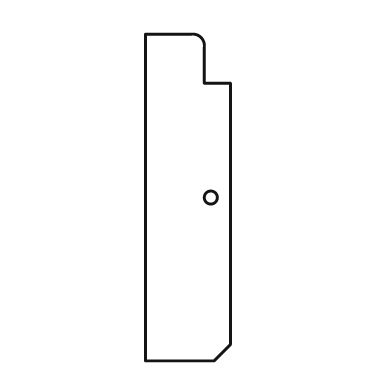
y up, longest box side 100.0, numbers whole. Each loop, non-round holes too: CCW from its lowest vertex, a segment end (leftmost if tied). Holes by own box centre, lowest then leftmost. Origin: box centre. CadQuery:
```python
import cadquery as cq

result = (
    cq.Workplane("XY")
    .moveTo(-13.0, -50.0)
    .lineTo(8.0, -50.0)
    .lineTo(13.0, -45.0)
    .lineTo(13.0, 35.0)
    .lineTo(5.0, 35.0)
    .lineTo(5.0, 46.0)
    .threePointArc((4.0, 49.0), (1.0, 50.0))
    .lineTo(-13.0, 50.0)
    .close()
    .moveTo(7.0, 0.0)
    .circle(2.0)
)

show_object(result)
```